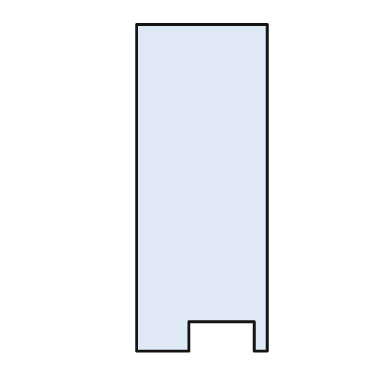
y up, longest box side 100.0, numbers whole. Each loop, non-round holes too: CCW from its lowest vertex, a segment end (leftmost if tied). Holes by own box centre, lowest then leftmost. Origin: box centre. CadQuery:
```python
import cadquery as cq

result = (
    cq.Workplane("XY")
    .moveTo(-20.0, -50.0)
    .lineTo(-4.0, -50.0)
    .lineTo(-4.0, -41.0)
    .lineTo(16.0, -41.0)
    .lineTo(16.0, -50.0)
    .lineTo(20.0, -50.0)
    .lineTo(20.0, 50.0)
    .lineTo(-20.0, 50.0)
    .close()
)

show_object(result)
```